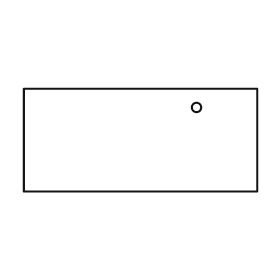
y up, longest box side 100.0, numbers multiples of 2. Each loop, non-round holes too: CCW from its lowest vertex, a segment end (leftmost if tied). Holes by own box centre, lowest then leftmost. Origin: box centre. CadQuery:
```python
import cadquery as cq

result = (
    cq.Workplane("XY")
    .moveTo(-50.0, -22.0)
    .lineTo(50.0, -22.0)
    .lineTo(50.0, 22.0)
    .lineTo(-50.0, 22.0)
    .close()
    .moveTo(24.0, 14.0)
    .circle(2.0)
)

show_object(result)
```